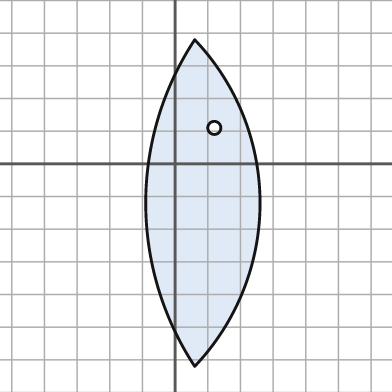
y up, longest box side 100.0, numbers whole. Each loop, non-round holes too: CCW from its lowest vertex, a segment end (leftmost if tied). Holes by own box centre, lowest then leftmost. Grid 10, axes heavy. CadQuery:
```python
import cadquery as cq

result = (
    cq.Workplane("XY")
    .moveTo(6.0, -62.0)
    .threePointArc((26.0, -12.0), (6.0, 38.0))
    .threePointArc((-9.0, -12.0), (6.0, -62.0))
    .close()
    .moveTo(12.0, 11.0)
    .circle(2.0)
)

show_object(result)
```